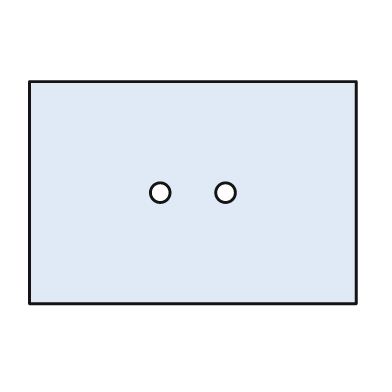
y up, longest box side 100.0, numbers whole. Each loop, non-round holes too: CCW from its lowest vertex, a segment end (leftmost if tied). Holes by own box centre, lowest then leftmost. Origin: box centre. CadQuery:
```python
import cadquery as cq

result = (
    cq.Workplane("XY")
    .moveTo(-50.0, -34.0)
    .lineTo(50.0, -34.0)
    .lineTo(50.0, 34.0)
    .lineTo(-50.0, 34.0)
    .close()
    .moveTo(-10.0, 0.0)
    .circle(3.0)
    .moveTo(10.0, 0.0)
    .circle(3.0)
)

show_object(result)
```